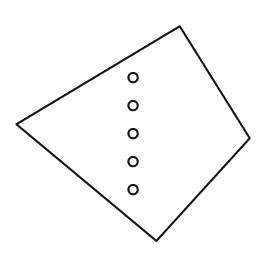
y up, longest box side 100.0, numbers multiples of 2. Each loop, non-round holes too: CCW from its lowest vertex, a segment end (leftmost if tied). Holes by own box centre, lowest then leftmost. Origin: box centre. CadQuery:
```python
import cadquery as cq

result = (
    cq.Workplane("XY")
    .moveTo(10.0, -46.0)
    .lineTo(50.0, -2.0)
    .lineTo(20.0, 46.0)
    .lineTo(-50.0, 4.0)
    .close()
    .moveTo(0.0, -24.0)
    .circle(2.0)
    .moveTo(0.0, -12.0)
    .circle(2.0)
    .moveTo(0.0, 0.0)
    .circle(2.0)
    .moveTo(0.0, 12.0)
    .circle(2.0)
    .moveTo(0.0, 24.0)
    .circle(2.0)
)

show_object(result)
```